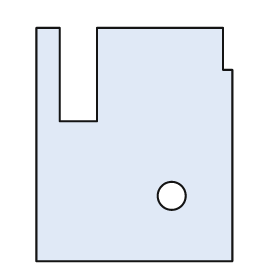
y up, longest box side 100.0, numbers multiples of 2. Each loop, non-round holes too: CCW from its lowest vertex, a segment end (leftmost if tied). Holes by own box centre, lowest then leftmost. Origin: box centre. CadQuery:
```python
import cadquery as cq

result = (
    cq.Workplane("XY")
    .moveTo(-42.0, -50.0)
    .lineTo(42.0, -50.0)
    .lineTo(42.0, 32.0)
    .lineTo(38.0, 32.0)
    .lineTo(38.0, 50.0)
    .lineTo(-16.0, 50.0)
    .lineTo(-16.0, 10.0)
    .lineTo(-32.0, 10.0)
    .lineTo(-32.0, 50.0)
    .lineTo(-42.0, 50.0)
    .close()
    .moveTo(16.0, -22.0)
    .circle(6.0)
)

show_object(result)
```